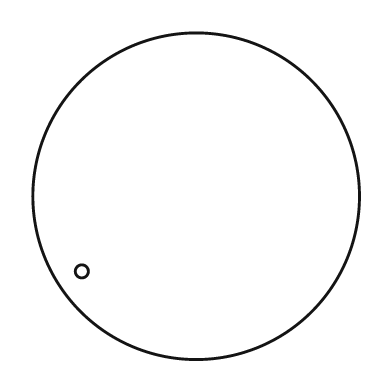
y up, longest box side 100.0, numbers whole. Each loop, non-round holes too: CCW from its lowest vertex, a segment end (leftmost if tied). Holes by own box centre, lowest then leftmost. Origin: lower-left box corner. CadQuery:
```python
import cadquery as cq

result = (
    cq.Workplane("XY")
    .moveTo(50.0, 50.0)
    .circle(50.0)
    .moveTo(15.0, 27.0)
    .circle(2.0)
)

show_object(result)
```